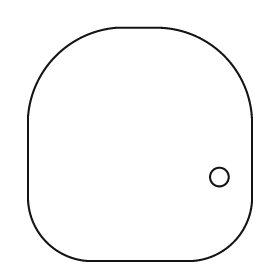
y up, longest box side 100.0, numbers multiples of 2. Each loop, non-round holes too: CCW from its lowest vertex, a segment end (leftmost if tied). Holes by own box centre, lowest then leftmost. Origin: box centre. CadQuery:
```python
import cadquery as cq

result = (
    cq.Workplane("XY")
    .moveTo(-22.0, -50.0)
    .lineTo(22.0, -50.0)
    .threePointArc((40.0, -42.0), (48.0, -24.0))
    .lineTo(48.0, 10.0)
    .threePointArc((36.0, 38.0), (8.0, 50.0))
    .lineTo(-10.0, 50.0)
    .threePointArc((-36.0, 38.0), (-48.0, 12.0))
    .lineTo(-48.0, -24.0)
    .threePointArc((-40.0, -42.0), (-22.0, -50.0))
    .close()
    .moveTo(34.0, -14.0)
    .circle(4.0)
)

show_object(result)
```